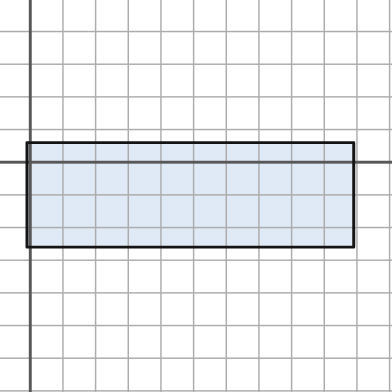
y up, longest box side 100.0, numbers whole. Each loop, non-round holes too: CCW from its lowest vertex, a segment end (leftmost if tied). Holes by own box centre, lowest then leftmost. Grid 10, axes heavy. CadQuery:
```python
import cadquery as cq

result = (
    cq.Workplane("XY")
    .moveTo(-1.0, -26.0)
    .lineTo(99.0, -26.0)
    .lineTo(99.0, 6.0)
    .lineTo(-1.0, 6.0)
    .close()
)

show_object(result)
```